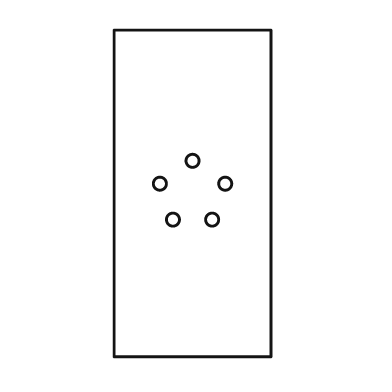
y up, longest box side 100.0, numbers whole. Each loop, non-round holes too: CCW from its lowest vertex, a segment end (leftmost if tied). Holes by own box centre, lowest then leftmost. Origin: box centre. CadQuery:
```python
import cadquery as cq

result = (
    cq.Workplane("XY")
    .moveTo(-24.0, -50.0)
    .lineTo(24.0, -50.0)
    .lineTo(24.0, 50.0)
    .lineTo(-24.0, 50.0)
    .close()
    .moveTo(-6.0, -8.0)
    .circle(2.0)
    .moveTo(6.0, -8.0)
    .circle(2.0)
    .moveTo(-10.0, 3.0)
    .circle(2.0)
    .moveTo(10.0, 3.0)
    .circle(2.0)
    .moveTo(0.0, 10.0)
    .circle(2.0)
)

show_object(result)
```